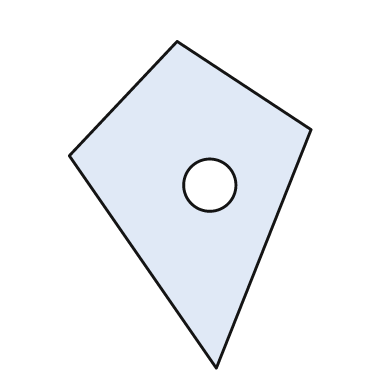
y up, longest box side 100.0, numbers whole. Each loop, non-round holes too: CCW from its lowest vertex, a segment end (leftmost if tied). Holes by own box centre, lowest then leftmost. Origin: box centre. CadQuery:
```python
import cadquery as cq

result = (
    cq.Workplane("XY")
    .moveTo(8.0, -50.0)
    .lineTo(37.0, 23.0)
    .lineTo(-4.0, 50.0)
    .lineTo(-37.0, 15.0)
    .close()
    .moveTo(6.0, 6.0)
    .circle(8.0)
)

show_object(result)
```